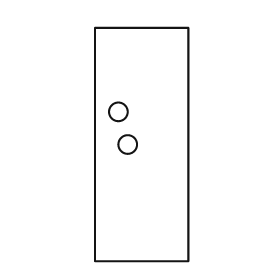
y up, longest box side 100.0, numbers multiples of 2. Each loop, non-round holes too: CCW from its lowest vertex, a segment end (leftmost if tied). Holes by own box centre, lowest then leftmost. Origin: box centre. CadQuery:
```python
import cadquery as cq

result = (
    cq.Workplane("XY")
    .moveTo(-20.0, -50.0)
    .lineTo(20.0, -50.0)
    .lineTo(20.0, 50.0)
    .lineTo(-20.0, 50.0)
    .close()
    .moveTo(-6.0, 0.0)
    .circle(4.0)
    .moveTo(-10.0, 14.0)
    .circle(4.0)
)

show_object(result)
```